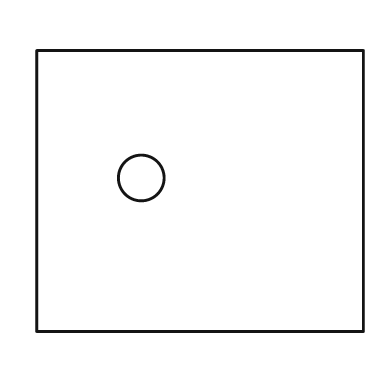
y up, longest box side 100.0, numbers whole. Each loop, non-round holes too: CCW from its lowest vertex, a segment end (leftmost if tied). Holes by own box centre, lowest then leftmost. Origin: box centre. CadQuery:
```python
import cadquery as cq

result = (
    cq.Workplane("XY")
    .moveTo(-50.0, -43.0)
    .lineTo(50.0, -43.0)
    .lineTo(50.0, 43.0)
    .lineTo(-50.0, 43.0)
    .close()
    .moveTo(-18.0, 4.0)
    .circle(7.0)
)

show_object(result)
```